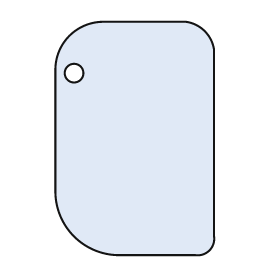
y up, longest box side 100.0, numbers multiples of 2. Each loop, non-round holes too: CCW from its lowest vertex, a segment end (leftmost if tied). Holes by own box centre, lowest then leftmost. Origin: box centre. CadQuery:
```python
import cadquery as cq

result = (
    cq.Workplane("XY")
    .moveTo(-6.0, -50.0)
    .lineTo(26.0, -50.0)
    .threePointArc((32.0, -48.0), (34.0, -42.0))
    .lineTo(34.0, 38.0)
    .threePointArc((30.0, 46.0), (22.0, 50.0))
    .lineTo(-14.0, 50.0)
    .threePointArc((-28.0, 44.0), (-34.0, 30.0))
    .lineTo(-34.0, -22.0)
    .threePointArc((-26.0, -42.0), (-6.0, -50.0))
    .close()
    .moveTo(-26.0, 28.0)
    .circle(4.0)
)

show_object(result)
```